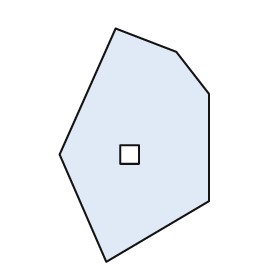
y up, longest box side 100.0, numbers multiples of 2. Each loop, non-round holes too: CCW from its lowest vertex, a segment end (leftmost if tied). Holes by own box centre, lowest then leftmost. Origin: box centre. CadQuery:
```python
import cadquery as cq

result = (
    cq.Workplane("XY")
    .moveTo(-12.0, -50.0)
    .lineTo(32.0, -24.0)
    .lineTo(32.0, 22.0)
    .lineTo(18.0, 40.0)
    .lineTo(-8.0, 50.0)
    .lineTo(-32.0, -4.0)
    .close()
    .moveTo(-6.0, -8.0)
    .lineTo(2.0, -8.0)
    .lineTo(2.0, 0.0)
    .lineTo(-6.0, 0.0)
    .close()
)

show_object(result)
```